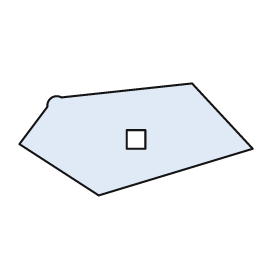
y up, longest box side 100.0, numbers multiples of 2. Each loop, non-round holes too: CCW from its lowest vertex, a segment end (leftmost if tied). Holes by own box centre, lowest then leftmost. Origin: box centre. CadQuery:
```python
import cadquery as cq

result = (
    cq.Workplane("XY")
    .moveTo(-16.0, -24.0)
    .lineTo(50.0, -4.0)
    .lineTo(24.0, 24.0)
    .lineTo(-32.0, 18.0)
    .threePointArc((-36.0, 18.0), (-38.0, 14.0))
    .lineTo(-50.0, -2.0)
    .close()
    .moveTo(-4.0, -4.0)
    .lineTo(4.0, -4.0)
    .lineTo(4.0, 4.0)
    .lineTo(-4.0, 4.0)
    .close()
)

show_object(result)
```